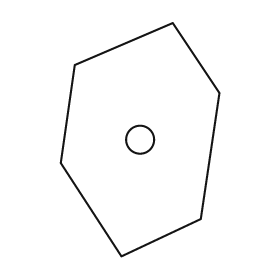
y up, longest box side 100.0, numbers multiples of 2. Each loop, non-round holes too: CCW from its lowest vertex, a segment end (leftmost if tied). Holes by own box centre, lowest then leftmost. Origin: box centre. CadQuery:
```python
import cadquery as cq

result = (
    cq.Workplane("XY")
    .moveTo(-8.0, -50.0)
    .lineTo(26.0, -34.0)
    .lineTo(34.0, 20.0)
    .lineTo(14.0, 50.0)
    .lineTo(-28.0, 32.0)
    .lineTo(-34.0, -10.0)
    .close()
    .moveTo(0.0, 0.0)
    .circle(6.0)
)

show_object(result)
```